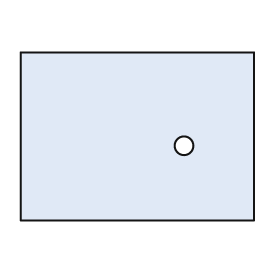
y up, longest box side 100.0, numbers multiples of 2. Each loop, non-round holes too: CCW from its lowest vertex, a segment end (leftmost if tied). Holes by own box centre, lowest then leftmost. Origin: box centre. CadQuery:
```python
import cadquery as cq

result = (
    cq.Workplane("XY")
    .moveTo(-50.0, -36.0)
    .lineTo(50.0, -36.0)
    .lineTo(50.0, 36.0)
    .lineTo(-50.0, 36.0)
    .close()
    .moveTo(20.0, -4.0)
    .circle(4.0)
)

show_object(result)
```